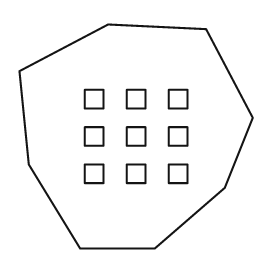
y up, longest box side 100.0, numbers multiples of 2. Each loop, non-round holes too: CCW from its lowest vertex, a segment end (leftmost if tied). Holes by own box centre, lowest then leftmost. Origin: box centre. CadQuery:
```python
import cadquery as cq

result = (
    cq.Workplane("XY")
    .moveTo(-24.0, -48.0)
    .lineTo(8.0, -48.0)
    .lineTo(38.0, -22.0)
    .lineTo(50.0, 8.0)
    .lineTo(30.0, 46.0)
    .lineTo(-12.0, 48.0)
    .lineTo(-50.0, 28.0)
    .lineTo(-46.0, -12.0)
    .close()
    .moveTo(-22.0, -20.0)
    .lineTo(-14.0, -20.0)
    .lineTo(-14.0, -12.0)
    .lineTo(-22.0, -12.0)
    .close()
    .moveTo(-4.0, -20.0)
    .lineTo(4.0, -20.0)
    .lineTo(4.0, -12.0)
    .lineTo(-4.0, -12.0)
    .close()
    .moveTo(14.0, -20.0)
    .lineTo(22.0, -20.0)
    .lineTo(22.0, -12.0)
    .lineTo(14.0, -12.0)
    .close()
    .moveTo(-22.0, -4.0)
    .lineTo(-14.0, -4.0)
    .lineTo(-14.0, 4.0)
    .lineTo(-22.0, 4.0)
    .close()
    .moveTo(-4.0, -4.0)
    .lineTo(4.0, -4.0)
    .lineTo(4.0, 4.0)
    .lineTo(-4.0, 4.0)
    .close()
    .moveTo(14.0, -4.0)
    .lineTo(22.0, -4.0)
    .lineTo(22.0, 4.0)
    .lineTo(14.0, 4.0)
    .close()
    .moveTo(-22.0, 12.0)
    .lineTo(-14.0, 12.0)
    .lineTo(-14.0, 20.0)
    .lineTo(-22.0, 20.0)
    .close()
    .moveTo(-4.0, 12.0)
    .lineTo(4.0, 12.0)
    .lineTo(4.0, 20.0)
    .lineTo(-4.0, 20.0)
    .close()
    .moveTo(14.0, 12.0)
    .lineTo(22.0, 12.0)
    .lineTo(22.0, 20.0)
    .lineTo(14.0, 20.0)
    .close()
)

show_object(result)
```